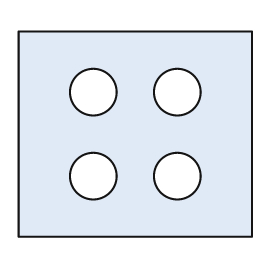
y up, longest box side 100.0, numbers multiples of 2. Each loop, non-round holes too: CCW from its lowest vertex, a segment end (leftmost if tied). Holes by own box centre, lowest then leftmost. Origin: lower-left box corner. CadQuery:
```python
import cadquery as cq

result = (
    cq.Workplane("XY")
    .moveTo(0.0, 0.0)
    .lineTo(100.0, 0.0)
    .lineTo(100.0, 88.0)
    .lineTo(0.0, 88.0)
    .close()
    .moveTo(32.0, 26.0)
    .circle(10.0)
    .moveTo(68.0, 26.0)
    .circle(10.0)
    .moveTo(32.0, 62.0)
    .circle(10.0)
    .moveTo(68.0, 62.0)
    .circle(10.0)
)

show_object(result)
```